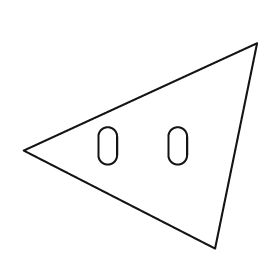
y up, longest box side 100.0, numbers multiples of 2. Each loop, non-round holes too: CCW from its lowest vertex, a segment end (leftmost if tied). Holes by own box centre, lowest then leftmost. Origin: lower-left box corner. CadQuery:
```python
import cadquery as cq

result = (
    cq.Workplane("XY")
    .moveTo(82.0, 0.0)
    .lineTo(100.0, 88.0)
    .lineTo(0.0, 42.0)
    .close()
    .moveTo(32.0, 40.0)
    .threePointArc((36.0, 36.0), (40.0, 40.0))
    .lineTo(40.0, 48.0)
    .threePointArc((36.0, 52.0), (32.0, 48.0))
    .close()
    .moveTo(62.0, 40.0)
    .threePointArc((66.0, 36.0), (70.0, 40.0))
    .lineTo(70.0, 48.0)
    .threePointArc((66.0, 52.0), (62.0, 48.0))
    .close()
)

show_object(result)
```